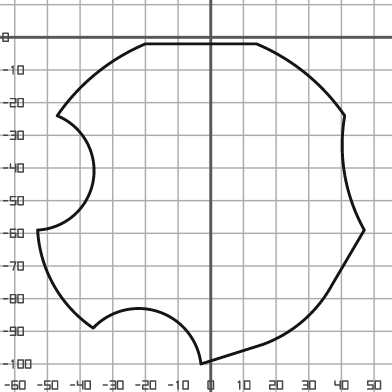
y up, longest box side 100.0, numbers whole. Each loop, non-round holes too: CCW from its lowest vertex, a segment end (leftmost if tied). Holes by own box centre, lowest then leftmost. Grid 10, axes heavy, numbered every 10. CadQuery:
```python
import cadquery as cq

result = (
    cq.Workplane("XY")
    .moveTo(-3.0, -100.0)
    .lineTo(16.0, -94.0)
    .threePointArc((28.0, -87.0), (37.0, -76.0))
    .lineTo(47.0, -59.0)
    .threePointArc((41.0, -42.0), (41.0, -24.0))
    .threePointArc((29.0, -11.0), (14.0, -2.0))
    .lineTo(-20.0, -2.0)
    .threePointArc((-35.0, -11.0), (-47.0, -24.0))
    .threePointArc((-36.0, -44.0), (-53.0, -59.0))
    .threePointArc((-48.0, -76.0), (-36.0, -89.0))
    .threePointArc((-16.0, -84.0), (-3.0, -100.0))
    .close()
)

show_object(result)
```